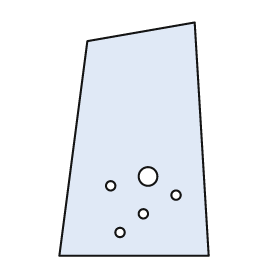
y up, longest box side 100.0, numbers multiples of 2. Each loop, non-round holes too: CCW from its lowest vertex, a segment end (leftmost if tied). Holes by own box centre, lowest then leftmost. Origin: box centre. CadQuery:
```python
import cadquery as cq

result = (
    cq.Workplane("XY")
    .moveTo(-32.0, -50.0)
    .lineTo(32.0, -50.0)
    .lineTo(26.0, 50.0)
    .lineTo(-20.0, 42.0)
    .close()
    .moveTo(-6.0, -40.0)
    .circle(2.0)
    .moveTo(4.0, -32.0)
    .circle(2.0)
    .moveTo(18.0, -24.0)
    .circle(2.0)
    .moveTo(-10.0, -20.0)
    .circle(2.0)
    .moveTo(6.0, -16.0)
    .circle(4.0)
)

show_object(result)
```